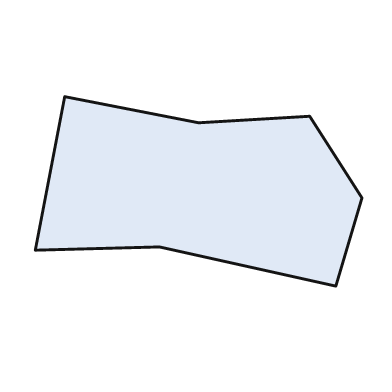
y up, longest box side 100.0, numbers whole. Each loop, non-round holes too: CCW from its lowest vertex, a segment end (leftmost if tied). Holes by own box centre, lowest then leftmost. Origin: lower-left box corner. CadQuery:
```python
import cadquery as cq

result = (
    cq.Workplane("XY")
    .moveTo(92.0, 0.0)
    .lineTo(100.0, 27.0)
    .lineTo(84.0, 52.0)
    .lineTo(50.0, 50.0)
    .lineTo(9.0, 58.0)
    .lineTo(0.0, 11.0)
    .lineTo(38.0, 12.0)
    .close()
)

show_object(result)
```